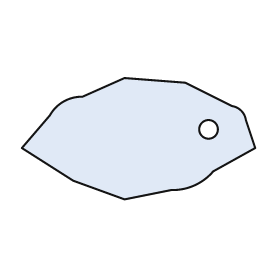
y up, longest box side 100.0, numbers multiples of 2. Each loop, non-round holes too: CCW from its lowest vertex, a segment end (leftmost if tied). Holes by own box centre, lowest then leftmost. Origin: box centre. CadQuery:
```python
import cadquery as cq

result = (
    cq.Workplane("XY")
    .moveTo(-6.0, -26.0)
    .lineTo(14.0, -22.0)
    .threePointArc((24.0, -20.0), (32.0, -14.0))
    .lineTo(50.0, -4.0)
    .lineTo(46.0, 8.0)
    .threePointArc((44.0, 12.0), (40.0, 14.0))
    .lineTo(20.0, 24.0)
    .lineTo(-6.0, 26.0)
    .lineTo(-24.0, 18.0)
    .threePointArc((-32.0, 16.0), (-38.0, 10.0))
    .lineTo(-50.0, -4.0)
    .lineTo(-28.0, -18.0)
    .close()
    .moveTo(30.0, 4.0)
    .circle(4.0)
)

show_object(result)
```